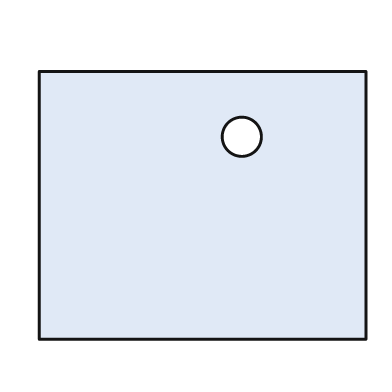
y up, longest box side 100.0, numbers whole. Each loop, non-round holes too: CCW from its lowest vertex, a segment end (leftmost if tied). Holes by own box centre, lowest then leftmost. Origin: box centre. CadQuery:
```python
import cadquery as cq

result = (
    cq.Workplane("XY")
    .moveTo(-50.0, -41.0)
    .lineTo(50.0, -41.0)
    .lineTo(50.0, 41.0)
    .lineTo(-50.0, 41.0)
    .close()
    .moveTo(12.0, 21.0)
    .circle(6.0)
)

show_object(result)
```